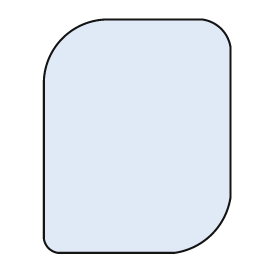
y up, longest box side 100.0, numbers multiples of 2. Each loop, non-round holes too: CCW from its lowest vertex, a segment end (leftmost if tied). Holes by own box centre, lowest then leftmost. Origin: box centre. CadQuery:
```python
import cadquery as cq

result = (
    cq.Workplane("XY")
    .moveTo(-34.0, -50.0)
    .lineTo(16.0, -50.0)
    .threePointArc((32.0, -42.0), (40.0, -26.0))
    .lineTo(40.0, 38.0)
    .threePointArc((36.0, 46.0), (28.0, 50.0))
    .lineTo(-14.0, 50.0)
    .threePointArc((-32.0, 42.0), (-40.0, 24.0))
    .lineTo(-40.0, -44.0)
    .threePointArc((-38.0, -48.0), (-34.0, -50.0))
    .close()
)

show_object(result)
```